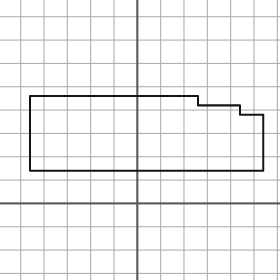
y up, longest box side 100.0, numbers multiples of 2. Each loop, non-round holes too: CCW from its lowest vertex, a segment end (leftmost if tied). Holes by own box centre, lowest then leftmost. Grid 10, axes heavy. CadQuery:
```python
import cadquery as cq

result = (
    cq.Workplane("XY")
    .moveTo(-46.0, 14.0)
    .lineTo(54.0, 14.0)
    .lineTo(54.0, 38.0)
    .lineTo(44.0, 38.0)
    .lineTo(44.0, 42.0)
    .lineTo(26.0, 42.0)
    .lineTo(26.0, 46.0)
    .lineTo(-46.0, 46.0)
    .close()
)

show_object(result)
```